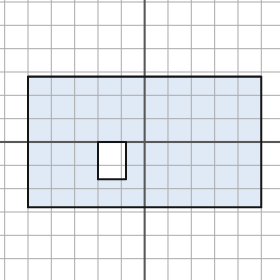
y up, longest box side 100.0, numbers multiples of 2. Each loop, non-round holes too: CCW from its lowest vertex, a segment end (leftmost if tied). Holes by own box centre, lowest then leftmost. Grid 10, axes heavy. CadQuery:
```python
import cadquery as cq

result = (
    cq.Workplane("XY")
    .moveTo(-50.0, -28.0)
    .lineTo(50.0, -28.0)
    .lineTo(50.0, 28.0)
    .lineTo(-50.0, 28.0)
    .close()
    .moveTo(-20.0, -16.0)
    .lineTo(-8.0, -16.0)
    .lineTo(-8.0, 0.0)
    .lineTo(-20.0, 0.0)
    .close()
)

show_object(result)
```